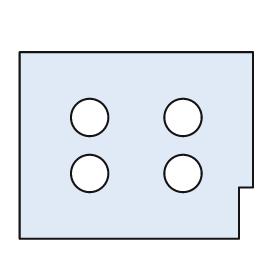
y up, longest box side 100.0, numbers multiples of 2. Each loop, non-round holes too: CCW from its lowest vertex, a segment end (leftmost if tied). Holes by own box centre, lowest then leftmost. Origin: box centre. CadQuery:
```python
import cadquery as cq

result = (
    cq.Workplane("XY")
    .moveTo(-50.0, -40.0)
    .lineTo(44.0, -40.0)
    .lineTo(44.0, -18.0)
    .lineTo(50.0, -18.0)
    .lineTo(50.0, 40.0)
    .lineTo(-50.0, 40.0)
    .close()
    .moveTo(-20.0, -12.0)
    .circle(8.0)
    .moveTo(20.0, -12.0)
    .circle(8.0)
    .moveTo(-20.0, 12.0)
    .circle(8.0)
    .moveTo(20.0, 12.0)
    .circle(8.0)
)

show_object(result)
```